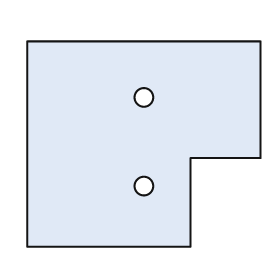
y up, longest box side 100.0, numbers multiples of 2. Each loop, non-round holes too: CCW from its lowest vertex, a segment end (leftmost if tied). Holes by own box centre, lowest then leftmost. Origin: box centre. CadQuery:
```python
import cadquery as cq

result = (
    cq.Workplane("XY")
    .moveTo(-50.0, -44.0)
    .lineTo(20.0, -44.0)
    .lineTo(20.0, -6.0)
    .lineTo(50.0, -6.0)
    .lineTo(50.0, 44.0)
    .lineTo(-50.0, 44.0)
    .close()
    .moveTo(0.0, -18.0)
    .circle(4.0)
    .moveTo(0.0, 20.0)
    .circle(4.0)
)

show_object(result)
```